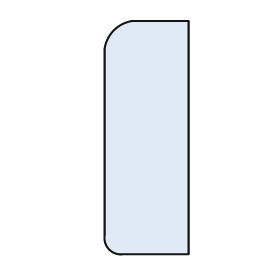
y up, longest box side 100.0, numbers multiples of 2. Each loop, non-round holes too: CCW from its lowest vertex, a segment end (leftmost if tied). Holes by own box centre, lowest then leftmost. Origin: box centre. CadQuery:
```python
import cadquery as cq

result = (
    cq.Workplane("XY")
    .moveTo(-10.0, -50.0)
    .lineTo(18.0, -50.0)
    .lineTo(18.0, 50.0)
    .lineTo(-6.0, 50.0)
    .threePointArc((-14.0, 46.0), (-18.0, 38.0))
    .lineTo(-18.0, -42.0)
    .threePointArc((-16.0, -48.0), (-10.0, -50.0))
    .close()
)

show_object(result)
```